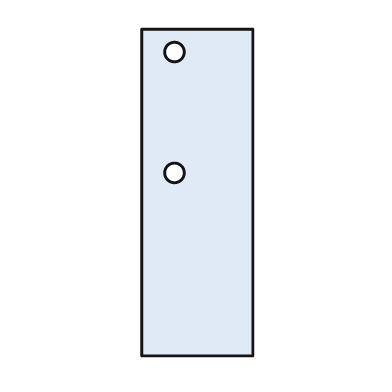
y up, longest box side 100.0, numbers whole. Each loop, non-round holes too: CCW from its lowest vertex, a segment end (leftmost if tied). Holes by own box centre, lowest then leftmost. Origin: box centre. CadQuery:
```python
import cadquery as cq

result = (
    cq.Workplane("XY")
    .moveTo(-17.0, -50.0)
    .lineTo(17.0, -50.0)
    .lineTo(17.0, 50.0)
    .lineTo(-17.0, 50.0)
    .close()
    .moveTo(-7.0, 6.0)
    .circle(3.0)
    .moveTo(-7.0, 43.0)
    .circle(3.0)
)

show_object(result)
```